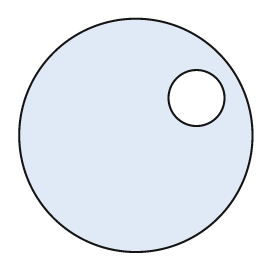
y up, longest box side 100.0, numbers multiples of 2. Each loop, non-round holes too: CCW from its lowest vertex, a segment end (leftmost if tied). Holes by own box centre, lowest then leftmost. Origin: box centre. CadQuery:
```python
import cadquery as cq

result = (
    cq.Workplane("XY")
    .moveTo(0.0, 0.0)
    .circle(50.0)
    .moveTo(26.0, 16.0)
    .circle(12.0)
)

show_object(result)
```